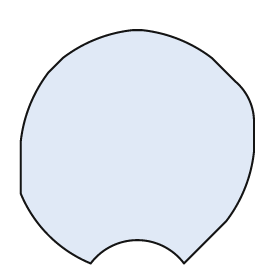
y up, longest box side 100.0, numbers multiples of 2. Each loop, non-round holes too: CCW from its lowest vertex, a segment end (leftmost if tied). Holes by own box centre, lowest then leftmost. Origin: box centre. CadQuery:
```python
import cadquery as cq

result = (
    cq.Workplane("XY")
    .moveTo(-20.0, -50.0)
    .threePointArc((0.0, -40.0), (20.0, -50.0))
    .lineTo(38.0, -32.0)
    .threePointArc((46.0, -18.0), (50.0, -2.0))
    .lineTo(50.0, 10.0)
    .threePointArc((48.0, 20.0), (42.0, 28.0))
    .lineTo(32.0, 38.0)
    .threePointArc((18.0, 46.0), (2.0, 50.0))
    .lineTo(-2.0, 50.0)
    .threePointArc((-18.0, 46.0), (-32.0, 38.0))
    .lineTo(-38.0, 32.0)
    .threePointArc((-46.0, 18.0), (-50.0, 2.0))
    .lineTo(-50.0, -20.0)
    .threePointArc((-38.0, -38.0), (-20.0, -50.0))
    .close()
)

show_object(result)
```